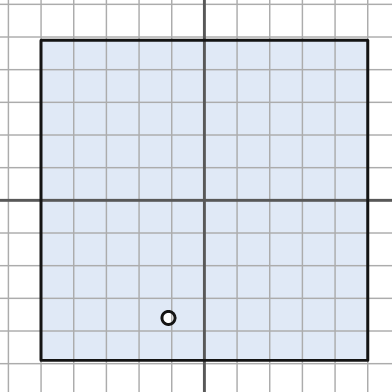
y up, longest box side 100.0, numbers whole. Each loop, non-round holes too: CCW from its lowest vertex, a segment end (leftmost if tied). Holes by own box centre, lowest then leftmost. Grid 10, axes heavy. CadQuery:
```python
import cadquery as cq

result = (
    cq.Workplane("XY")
    .moveTo(-50.0, -49.0)
    .lineTo(50.0, -49.0)
    .lineTo(50.0, 49.0)
    .lineTo(-50.0, 49.0)
    .close()
    .moveTo(-11.0, -36.0)
    .circle(2.0)
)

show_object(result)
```